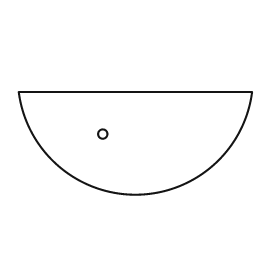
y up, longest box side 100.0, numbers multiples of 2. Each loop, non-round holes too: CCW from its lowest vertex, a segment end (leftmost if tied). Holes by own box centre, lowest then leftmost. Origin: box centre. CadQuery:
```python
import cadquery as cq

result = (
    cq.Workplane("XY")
    .moveTo(-50.0, 22.0)
    .threePointArc((0.0, -22.0), (50.0, 22.0))
    .close()
    .moveTo(-14.0, 4.0)
    .circle(2.0)
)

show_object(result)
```